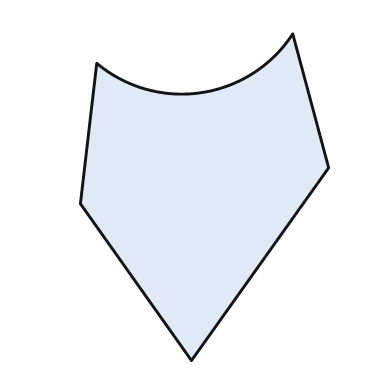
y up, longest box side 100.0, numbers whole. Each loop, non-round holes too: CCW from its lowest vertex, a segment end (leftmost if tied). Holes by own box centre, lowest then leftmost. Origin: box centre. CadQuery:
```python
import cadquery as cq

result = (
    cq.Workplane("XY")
    .moveTo(-4.0, -50.0)
    .lineTo(38.0, 9.0)
    .lineTo(27.0, 50.0)
    .threePointArc((-1.0, 32.0), (-33.0, 41.0))
    .lineTo(-38.0, -2.0)
    .close()
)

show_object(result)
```